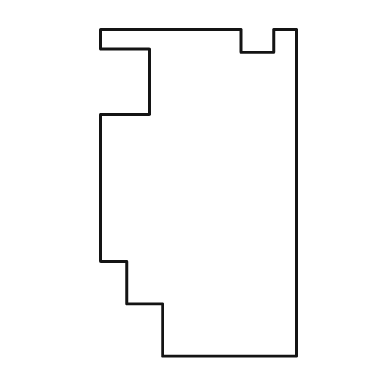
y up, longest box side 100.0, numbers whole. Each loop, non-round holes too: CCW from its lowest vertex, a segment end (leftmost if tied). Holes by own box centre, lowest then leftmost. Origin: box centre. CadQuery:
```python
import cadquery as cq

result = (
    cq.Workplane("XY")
    .moveTo(-11.0, -50.0)
    .lineTo(30.0, -50.0)
    .lineTo(30.0, 50.0)
    .lineTo(23.0, 50.0)
    .lineTo(23.0, 43.0)
    .lineTo(13.0, 43.0)
    .lineTo(13.0, 50.0)
    .lineTo(-30.0, 50.0)
    .lineTo(-30.0, 44.0)
    .lineTo(-15.0, 44.0)
    .lineTo(-15.0, 24.0)
    .lineTo(-30.0, 24.0)
    .lineTo(-30.0, -21.0)
    .lineTo(-22.0, -21.0)
    .lineTo(-22.0, -34.0)
    .lineTo(-11.0, -34.0)
    .close()
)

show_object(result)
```